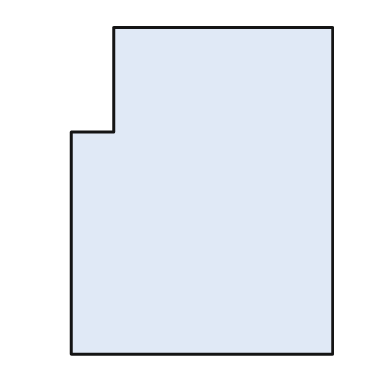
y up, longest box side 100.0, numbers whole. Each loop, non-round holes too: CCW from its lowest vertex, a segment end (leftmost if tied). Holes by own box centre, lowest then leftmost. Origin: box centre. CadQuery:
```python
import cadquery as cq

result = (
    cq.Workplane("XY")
    .moveTo(-40.0, -50.0)
    .lineTo(40.0, -50.0)
    .lineTo(40.0, 50.0)
    .lineTo(-27.0, 50.0)
    .lineTo(-27.0, 18.0)
    .lineTo(-40.0, 18.0)
    .close()
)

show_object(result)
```